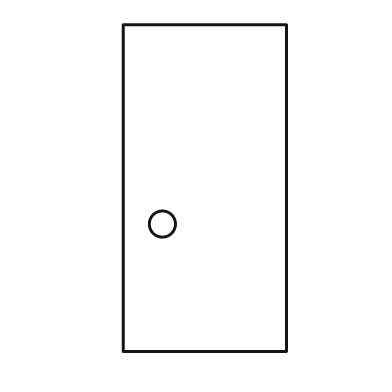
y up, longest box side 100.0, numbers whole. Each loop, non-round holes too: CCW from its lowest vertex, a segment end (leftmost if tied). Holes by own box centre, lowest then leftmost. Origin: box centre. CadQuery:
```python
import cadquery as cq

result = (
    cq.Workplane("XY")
    .moveTo(-25.0, -50.0)
    .lineTo(25.0, -50.0)
    .lineTo(25.0, 50.0)
    .lineTo(-25.0, 50.0)
    .close()
    .moveTo(-13.0, -11.0)
    .circle(4.0)
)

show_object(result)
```